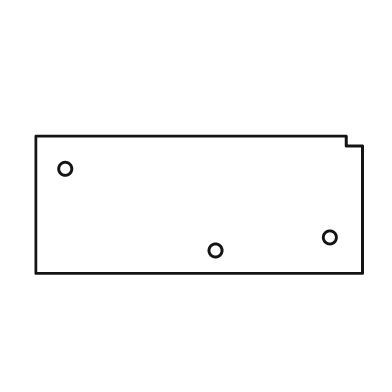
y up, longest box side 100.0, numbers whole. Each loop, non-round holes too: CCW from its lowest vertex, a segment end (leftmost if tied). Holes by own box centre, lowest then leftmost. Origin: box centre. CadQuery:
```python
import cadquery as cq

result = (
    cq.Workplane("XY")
    .moveTo(-50.0, -21.0)
    .lineTo(50.0, -21.0)
    .lineTo(50.0, 18.0)
    .lineTo(45.0, 18.0)
    .lineTo(45.0, 21.0)
    .lineTo(-50.0, 21.0)
    .close()
    .moveTo(5.0, -14.0)
    .circle(2.0)
    .moveTo(40.0, -10.0)
    .circle(2.0)
    .moveTo(-41.0, 11.0)
    .circle(2.0)
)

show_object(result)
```